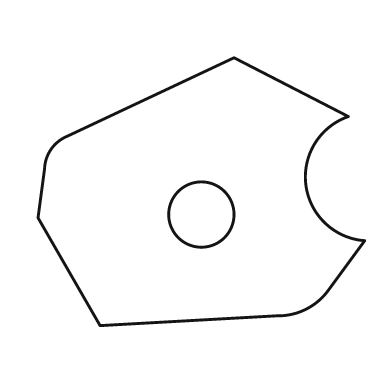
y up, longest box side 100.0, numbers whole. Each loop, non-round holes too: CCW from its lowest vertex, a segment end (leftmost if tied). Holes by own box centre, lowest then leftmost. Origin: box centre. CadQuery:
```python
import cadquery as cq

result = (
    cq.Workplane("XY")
    .moveTo(-31.0, -41.0)
    .lineTo(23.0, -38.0)
    .threePointArc((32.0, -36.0), (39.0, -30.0))
    .lineTo(50.0, -15.0)
    .threePointArc((32.0, 2.0), (45.0, 23.0))
    .lineTo(10.0, 41.0)
    .lineTo(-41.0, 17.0)
    .threePointArc((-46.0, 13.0), (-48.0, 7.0))
    .lineTo(-50.0, -8.0)
    .close()
    .moveTo(0.0, -7.0)
    .circle(10.0)
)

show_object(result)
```